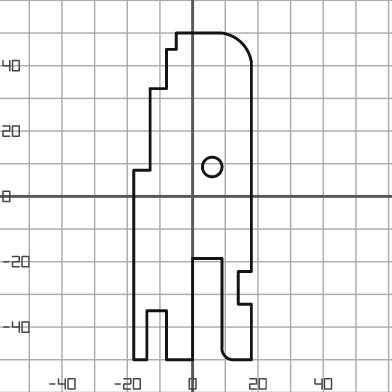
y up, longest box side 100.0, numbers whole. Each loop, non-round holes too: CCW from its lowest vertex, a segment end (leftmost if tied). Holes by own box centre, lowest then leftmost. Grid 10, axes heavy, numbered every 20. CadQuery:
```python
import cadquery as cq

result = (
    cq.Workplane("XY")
    .moveTo(-18.0, -50.0)
    .lineTo(-14.0, -50.0)
    .lineTo(-14.0, -35.0)
    .lineTo(-8.0, -35.0)
    .lineTo(-8.0, -50.0)
    .lineTo(0.0, -50.0)
    .lineTo(0.0, -19.0)
    .lineTo(9.0, -19.0)
    .lineTo(9.0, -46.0)
    .threePointArc((10.0, -49.0), (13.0, -50.0))
    .lineTo(18.0, -50.0)
    .lineTo(18.0, -33.0)
    .lineTo(14.0, -33.0)
    .lineTo(14.0, -23.0)
    .lineTo(18.0, -23.0)
    .lineTo(18.0, 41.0)
    .threePointArc((15.0, 47.0), (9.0, 50.0))
    .lineTo(-5.0, 50.0)
    .lineTo(-5.0, 45.0)
    .lineTo(-8.0, 45.0)
    .lineTo(-8.0, 33.0)
    .lineTo(-13.0, 33.0)
    .lineTo(-13.0, 8.0)
    .lineTo(-18.0, 8.0)
    .close()
    .moveTo(6.0, 9.0)
    .circle(3.0)
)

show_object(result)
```